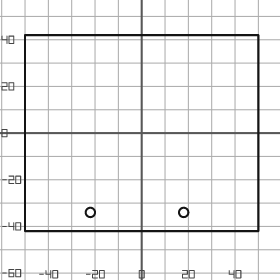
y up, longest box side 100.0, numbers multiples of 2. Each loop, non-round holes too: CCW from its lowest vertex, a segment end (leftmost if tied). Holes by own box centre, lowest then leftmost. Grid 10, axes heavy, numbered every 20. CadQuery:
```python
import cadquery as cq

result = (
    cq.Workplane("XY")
    .moveTo(-50.0, -42.0)
    .lineTo(50.0, -42.0)
    .lineTo(50.0, 42.0)
    .lineTo(-50.0, 42.0)
    .close()
    .moveTo(-22.0, -34.0)
    .circle(2.0)
    .moveTo(18.0, -34.0)
    .circle(2.0)
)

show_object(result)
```